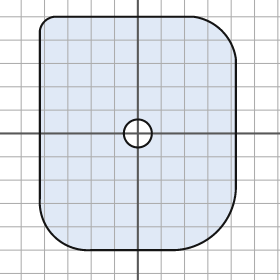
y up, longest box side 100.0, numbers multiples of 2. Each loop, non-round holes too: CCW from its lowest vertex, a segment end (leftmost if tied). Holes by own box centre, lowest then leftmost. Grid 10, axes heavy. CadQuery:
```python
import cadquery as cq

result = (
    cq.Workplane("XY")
    .moveTo(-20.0, -50.0)
    .lineTo(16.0, -50.0)
    .threePointArc((34.0, -42.0), (42.0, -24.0))
    .lineTo(42.0, 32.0)
    .threePointArc((36.0, 44.0), (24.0, 50.0))
    .lineTo(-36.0, 50.0)
    .threePointArc((-40.0, 48.0), (-42.0, 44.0))
    .lineTo(-42.0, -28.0)
    .threePointArc((-36.0, -44.0), (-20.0, -50.0))
    .close()
    .moveTo(0.0, 0.0)
    .circle(6.0)
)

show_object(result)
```